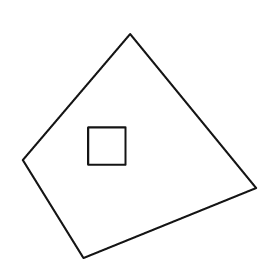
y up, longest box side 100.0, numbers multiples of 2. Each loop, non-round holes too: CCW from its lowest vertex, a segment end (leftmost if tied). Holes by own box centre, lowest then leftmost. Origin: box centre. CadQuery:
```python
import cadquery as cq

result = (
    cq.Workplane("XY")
    .moveTo(-24.0, -48.0)
    .lineTo(50.0, -18.0)
    .lineTo(-4.0, 48.0)
    .lineTo(-50.0, -6.0)
    .close()
    .moveTo(-22.0, -8.0)
    .lineTo(-6.0, -8.0)
    .lineTo(-6.0, 8.0)
    .lineTo(-22.0, 8.0)
    .close()
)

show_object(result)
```